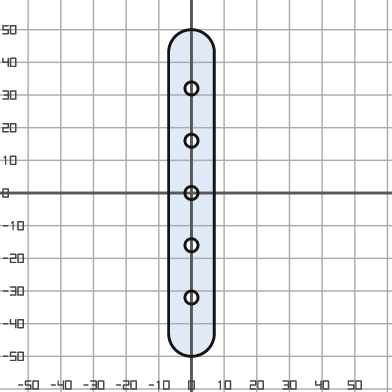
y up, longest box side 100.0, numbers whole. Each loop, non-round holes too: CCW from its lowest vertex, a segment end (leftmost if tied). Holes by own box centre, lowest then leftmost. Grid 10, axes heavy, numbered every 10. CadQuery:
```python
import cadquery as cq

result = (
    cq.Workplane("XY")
    .moveTo(-7.0, -43.0)
    .threePointArc((0.0, -50.0), (7.0, -43.0))
    .lineTo(7.0, 43.0)
    .threePointArc((0.0, 50.0), (-7.0, 43.0))
    .close()
    .moveTo(0.0, -32.0)
    .circle(2.0)
    .moveTo(0.0, -16.0)
    .circle(2.0)
    .moveTo(0.0, 0.0)
    .circle(2.0)
    .moveTo(0.0, 16.0)
    .circle(2.0)
    .moveTo(0.0, 32.0)
    .circle(2.0)
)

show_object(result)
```